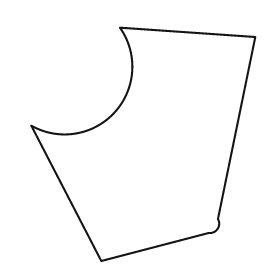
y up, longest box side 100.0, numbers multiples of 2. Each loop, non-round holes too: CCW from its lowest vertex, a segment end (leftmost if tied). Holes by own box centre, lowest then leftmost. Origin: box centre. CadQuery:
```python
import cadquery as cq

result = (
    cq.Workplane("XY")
    .moveTo(-18.0, -50.0)
    .lineTo(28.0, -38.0)
    .threePointArc((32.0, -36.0), (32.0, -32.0))
    .lineTo(48.0, 46.0)
    .lineTo(-10.0, 50.0)
    .threePointArc((-12.0, 14.0), (-48.0, 8.0))
    .close()
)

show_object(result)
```